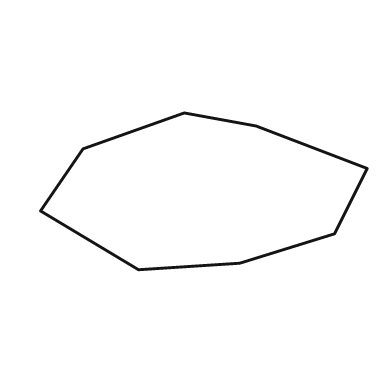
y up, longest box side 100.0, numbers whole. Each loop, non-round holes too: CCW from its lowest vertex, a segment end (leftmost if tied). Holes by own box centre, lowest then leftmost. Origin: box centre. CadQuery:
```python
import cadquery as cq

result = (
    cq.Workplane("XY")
    .moveTo(-20.0, -24.0)
    .lineTo(11.0, -22.0)
    .lineTo(40.0, -13.0)
    .lineTo(50.0, 7.0)
    .lineTo(16.0, 20.0)
    .lineTo(-6.0, 24.0)
    .lineTo(-37.0, 13.0)
    .lineTo(-50.0, -6.0)
    .close()
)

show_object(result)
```